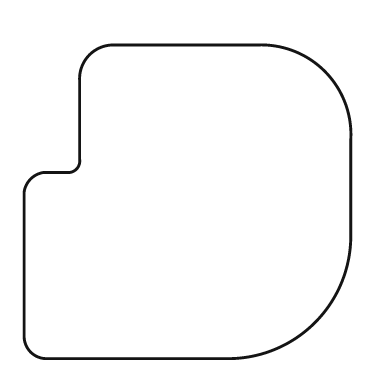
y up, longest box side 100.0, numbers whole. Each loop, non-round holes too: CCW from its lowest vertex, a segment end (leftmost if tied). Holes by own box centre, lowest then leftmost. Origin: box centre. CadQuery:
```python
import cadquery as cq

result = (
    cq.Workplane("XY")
    .moveTo(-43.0, -48.0)
    .lineTo(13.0, -48.0)
    .threePointArc((39.0, -37.0), (50.0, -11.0))
    .lineTo(50.0, 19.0)
    .threePointArc((42.0, 40.0), (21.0, 48.0))
    .lineTo(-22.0, 48.0)
    .threePointArc((-30.0, 45.0), (-33.0, 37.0))
    .lineTo(-33.0, 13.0)
    .threePointArc((-34.0, 10.0), (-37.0, 9.0))
    .lineTo(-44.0, 9.0)
    .threePointArc((-48.0, 7.0), (-50.0, 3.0))
    .lineTo(-50.0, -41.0)
    .threePointArc((-48.0, -46.0), (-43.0, -48.0))
    .close()
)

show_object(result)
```